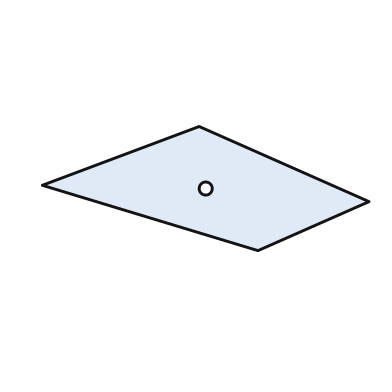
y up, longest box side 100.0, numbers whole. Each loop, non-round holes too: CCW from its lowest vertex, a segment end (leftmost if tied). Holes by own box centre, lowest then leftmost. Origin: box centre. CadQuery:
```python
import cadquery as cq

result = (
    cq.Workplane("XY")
    .moveTo(16.0, -19.0)
    .lineTo(50.0, -4.0)
    .lineTo(-2.0, 19.0)
    .lineTo(-50.0, 1.0)
    .close()
    .moveTo(0.0, 0.0)
    .circle(2.0)
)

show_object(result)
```